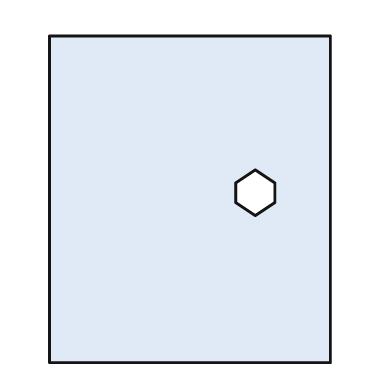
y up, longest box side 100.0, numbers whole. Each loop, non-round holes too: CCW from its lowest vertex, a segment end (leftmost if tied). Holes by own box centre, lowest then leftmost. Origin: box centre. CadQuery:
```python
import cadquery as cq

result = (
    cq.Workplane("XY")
    .moveTo(-43.0, -50.0)
    .lineTo(43.0, -50.0)
    .lineTo(43.0, 50.0)
    .lineTo(-43.0, 50.0)
    .close()
    .moveTo(20.0, -5.0)
    .lineTo(26.0, -1.0)
    .lineTo(26.0, 5.0)
    .lineTo(20.0, 9.0)
    .lineTo(14.0, 5.0)
    .lineTo(14.0, -1.0)
    .close()
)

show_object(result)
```